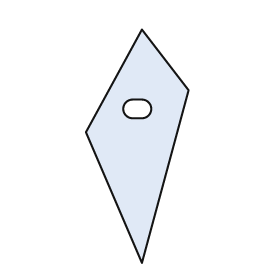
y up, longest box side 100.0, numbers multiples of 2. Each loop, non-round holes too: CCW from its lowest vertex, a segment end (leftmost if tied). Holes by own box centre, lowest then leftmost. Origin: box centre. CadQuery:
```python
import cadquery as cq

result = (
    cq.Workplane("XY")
    .moveTo(2.0, -50.0)
    .lineTo(22.0, 24.0)
    .lineTo(2.0, 50.0)
    .lineTo(-22.0, 6.0)
    .close()
    .moveTo(-2.0, 12.0)
    .lineTo(2.0, 12.0)
    .threePointArc((6.0, 16.0), (2.0, 20.0))
    .lineTo(-2.0, 20.0)
    .threePointArc((-6.0, 16.0), (-2.0, 12.0))
    .close()
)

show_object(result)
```